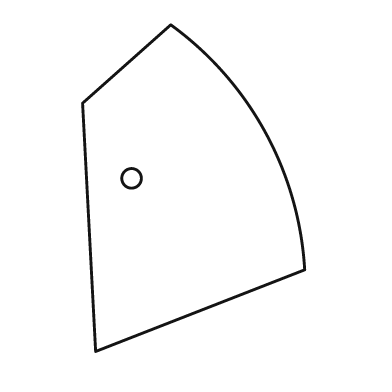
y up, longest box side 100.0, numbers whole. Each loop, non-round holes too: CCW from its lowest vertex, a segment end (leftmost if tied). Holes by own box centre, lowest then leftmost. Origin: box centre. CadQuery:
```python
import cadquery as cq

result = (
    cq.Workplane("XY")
    .moveTo(-30.0, -50.0)
    .lineTo(34.0, -25.0)
    .threePointArc((22.0, 17.0), (-7.0, 50.0))
    .lineTo(-34.0, 26.0)
    .close()
    .moveTo(-19.0, 3.0)
    .circle(3.0)
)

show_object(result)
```